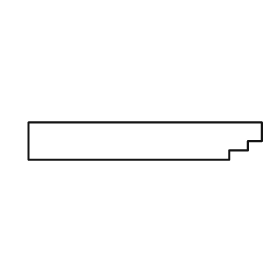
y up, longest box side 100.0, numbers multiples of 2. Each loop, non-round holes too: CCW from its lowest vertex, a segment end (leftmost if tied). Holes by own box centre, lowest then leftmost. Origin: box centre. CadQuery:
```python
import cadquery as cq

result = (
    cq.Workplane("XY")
    .moveTo(-50.0, -8.0)
    .lineTo(36.0, -8.0)
    .lineTo(36.0, -4.0)
    .lineTo(44.0, -4.0)
    .lineTo(44.0, 0.0)
    .lineTo(50.0, 0.0)
    .lineTo(50.0, 8.0)
    .lineTo(-50.0, 8.0)
    .close()
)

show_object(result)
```